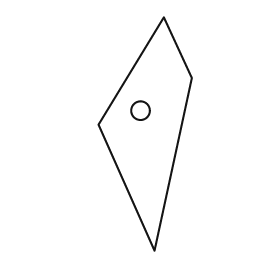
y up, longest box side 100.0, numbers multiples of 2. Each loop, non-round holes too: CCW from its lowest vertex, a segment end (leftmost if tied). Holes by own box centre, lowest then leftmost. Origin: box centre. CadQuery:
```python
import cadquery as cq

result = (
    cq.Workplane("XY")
    .moveTo(4.0, -50.0)
    .lineTo(20.0, 24.0)
    .lineTo(8.0, 50.0)
    .lineTo(-20.0, 4.0)
    .close()
    .moveTo(-2.0, 10.0)
    .circle(4.0)
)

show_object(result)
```